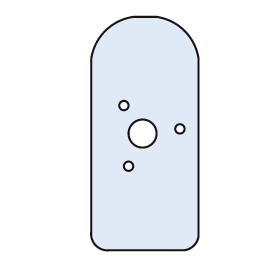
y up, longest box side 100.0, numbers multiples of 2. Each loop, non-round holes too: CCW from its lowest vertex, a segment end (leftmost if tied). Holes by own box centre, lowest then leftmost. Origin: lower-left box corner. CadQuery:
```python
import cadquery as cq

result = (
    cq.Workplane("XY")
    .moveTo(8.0, 0.0)
    .lineTo(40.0, 0.0)
    .threePointArc((44.0, 2.0), (46.0, 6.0))
    .lineTo(46.0, 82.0)
    .threePointArc((40.0, 94.0), (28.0, 100.0))
    .lineTo(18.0, 100.0)
    .threePointArc((6.0, 94.0), (0.0, 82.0))
    .lineTo(0.0, 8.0)
    .threePointArc((2.0, 2.0), (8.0, 0.0))
    .close()
    .moveTo(16.0, 36.0)
    .circle(2.0)
    .moveTo(22.0, 50.0)
    .circle(6.0)
    .moveTo(38.0, 52.0)
    .circle(2.0)
    .moveTo(14.0, 62.0)
    .circle(2.0)
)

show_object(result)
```